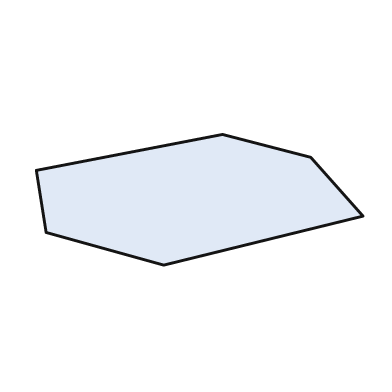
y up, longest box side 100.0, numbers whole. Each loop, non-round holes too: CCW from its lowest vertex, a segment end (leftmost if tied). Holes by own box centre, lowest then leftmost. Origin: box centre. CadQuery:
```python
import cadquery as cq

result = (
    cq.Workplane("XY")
    .moveTo(-11.0, -20.0)
    .lineTo(50.0, -5.0)
    .lineTo(34.0, 13.0)
    .lineTo(7.0, 20.0)
    .lineTo(-50.0, 9.0)
    .lineTo(-47.0, -10.0)
    .close()
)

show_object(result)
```